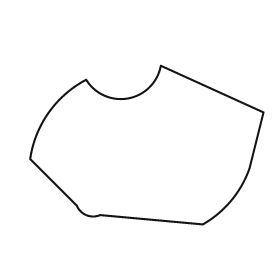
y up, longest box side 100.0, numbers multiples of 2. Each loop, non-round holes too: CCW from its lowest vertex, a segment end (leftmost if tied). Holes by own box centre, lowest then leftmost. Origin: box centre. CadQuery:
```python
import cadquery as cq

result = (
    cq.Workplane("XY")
    .moveTo(24.0, -34.0)
    .threePointArc((36.0, -24.0), (44.0, -10.0))
    .lineTo(50.0, 14.0)
    .lineTo(6.0, 34.0)
    .threePointArc((-8.0, 20.0), (-26.0, 28.0))
    .threePointArc((-42.0, 14.0), (-50.0, -6.0))
    .lineTo(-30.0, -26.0)
    .threePointArc((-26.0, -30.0), (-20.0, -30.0))
    .close()
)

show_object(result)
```